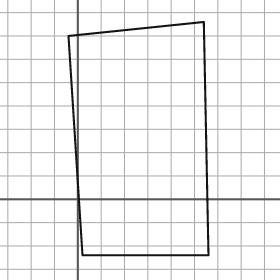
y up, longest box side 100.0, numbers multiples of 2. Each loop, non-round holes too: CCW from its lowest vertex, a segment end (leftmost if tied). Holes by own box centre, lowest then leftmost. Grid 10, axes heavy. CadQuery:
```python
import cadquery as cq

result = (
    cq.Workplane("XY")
    .moveTo(2.0, -24.0)
    .lineTo(56.0, -24.0)
    .lineTo(54.0, 76.0)
    .lineTo(-4.0, 70.0)
    .close()
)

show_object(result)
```